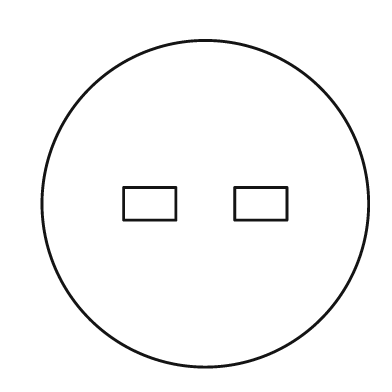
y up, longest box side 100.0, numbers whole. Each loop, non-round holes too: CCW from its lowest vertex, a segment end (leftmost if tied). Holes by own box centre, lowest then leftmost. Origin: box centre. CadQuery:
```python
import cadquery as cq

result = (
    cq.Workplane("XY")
    .moveTo(0.0, 0.0)
    .circle(50.0)
    .moveTo(-25.0, -5.0)
    .lineTo(-9.0, -5.0)
    .lineTo(-9.0, 5.0)
    .lineTo(-25.0, 5.0)
    .close()
    .moveTo(9.0, -5.0)
    .lineTo(25.0, -5.0)
    .lineTo(25.0, 5.0)
    .lineTo(9.0, 5.0)
    .close()
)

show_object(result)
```